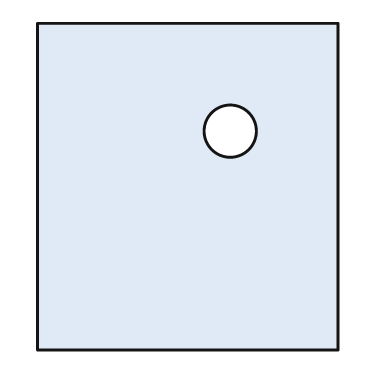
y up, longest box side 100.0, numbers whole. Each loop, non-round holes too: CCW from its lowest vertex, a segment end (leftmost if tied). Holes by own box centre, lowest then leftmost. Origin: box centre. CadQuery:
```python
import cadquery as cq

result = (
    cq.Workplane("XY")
    .moveTo(-46.0, -50.0)
    .lineTo(46.0, -50.0)
    .lineTo(46.0, 50.0)
    .lineTo(-46.0, 50.0)
    .close()
    .moveTo(13.0, 17.0)
    .circle(8.0)
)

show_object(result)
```